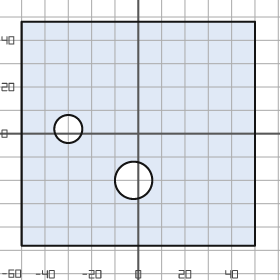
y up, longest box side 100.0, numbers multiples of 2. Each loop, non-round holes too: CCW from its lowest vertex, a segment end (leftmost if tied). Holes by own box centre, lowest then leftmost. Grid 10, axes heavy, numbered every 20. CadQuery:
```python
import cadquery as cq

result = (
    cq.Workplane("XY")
    .moveTo(-50.0, -48.0)
    .lineTo(50.0, -48.0)
    .lineTo(50.0, 48.0)
    .lineTo(-50.0, 48.0)
    .close()
    .moveTo(-2.0, -20.0)
    .circle(8.0)
    .moveTo(-30.0, 2.0)
    .circle(6.0)
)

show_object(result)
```